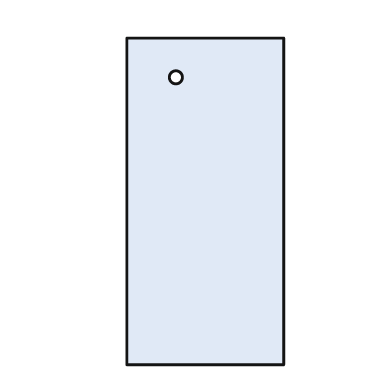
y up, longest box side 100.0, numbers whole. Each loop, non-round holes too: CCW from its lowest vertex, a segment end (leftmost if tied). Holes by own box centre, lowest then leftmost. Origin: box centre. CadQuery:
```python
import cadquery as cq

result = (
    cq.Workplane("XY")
    .moveTo(-24.0, -50.0)
    .lineTo(24.0, -50.0)
    .lineTo(24.0, 50.0)
    .lineTo(-24.0, 50.0)
    .close()
    .moveTo(-9.0, 38.0)
    .circle(2.0)
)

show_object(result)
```